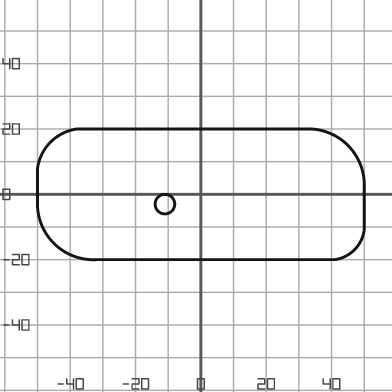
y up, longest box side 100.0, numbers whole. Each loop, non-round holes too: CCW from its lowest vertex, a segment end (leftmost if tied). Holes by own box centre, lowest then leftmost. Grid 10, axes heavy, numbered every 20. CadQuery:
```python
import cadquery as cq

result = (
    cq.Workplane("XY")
    .moveTo(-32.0, -20.0)
    .lineTo(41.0, -20.0)
    .threePointArc((47.0, -17.0), (50.0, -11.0))
    .lineTo(50.0, 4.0)
    .threePointArc((45.0, 15.0), (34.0, 20.0))
    .lineTo(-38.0, 20.0)
    .threePointArc((-46.0, 16.0), (-50.0, 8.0))
    .lineTo(-50.0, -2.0)
    .threePointArc((-45.0, -15.0), (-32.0, -20.0))
    .close()
    .moveTo(-11.0, -3.0)
    .circle(3.0)
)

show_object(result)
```